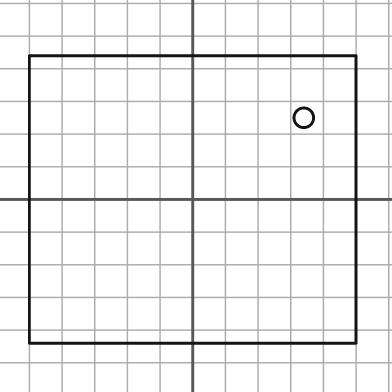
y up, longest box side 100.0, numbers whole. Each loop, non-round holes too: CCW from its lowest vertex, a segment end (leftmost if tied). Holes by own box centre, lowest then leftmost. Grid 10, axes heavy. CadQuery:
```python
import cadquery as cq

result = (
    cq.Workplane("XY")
    .moveTo(-50.0, -44.0)
    .lineTo(50.0, -44.0)
    .lineTo(50.0, 44.0)
    .lineTo(-50.0, 44.0)
    .close()
    .moveTo(34.0, 25.0)
    .circle(3.0)
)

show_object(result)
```